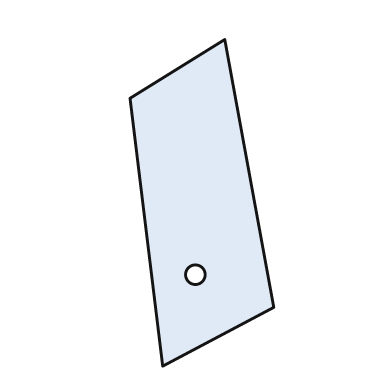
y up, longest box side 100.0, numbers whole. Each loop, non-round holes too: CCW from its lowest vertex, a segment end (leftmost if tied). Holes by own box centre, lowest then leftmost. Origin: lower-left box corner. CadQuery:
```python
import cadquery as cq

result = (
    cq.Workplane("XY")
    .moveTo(10.0, 0.0)
    .lineTo(44.0, 18.0)
    .lineTo(29.0, 100.0)
    .lineTo(0.0, 82.0)
    .close()
    .moveTo(20.0, 28.0)
    .circle(3.0)
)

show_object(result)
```